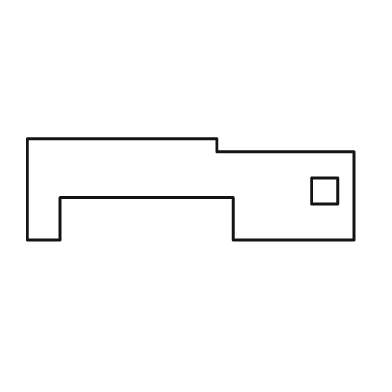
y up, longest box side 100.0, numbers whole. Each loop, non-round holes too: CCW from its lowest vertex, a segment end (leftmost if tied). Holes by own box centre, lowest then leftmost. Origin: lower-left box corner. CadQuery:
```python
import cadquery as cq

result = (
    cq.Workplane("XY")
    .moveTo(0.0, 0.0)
    .lineTo(10.0, 0.0)
    .lineTo(10.0, 13.0)
    .lineTo(63.0, 13.0)
    .lineTo(63.0, 0.0)
    .lineTo(100.0, 0.0)
    .lineTo(100.0, 27.0)
    .lineTo(58.0, 27.0)
    .lineTo(58.0, 31.0)
    .lineTo(0.0, 31.0)
    .close()
    .moveTo(87.0, 11.0)
    .lineTo(95.0, 11.0)
    .lineTo(95.0, 19.0)
    .lineTo(87.0, 19.0)
    .close()
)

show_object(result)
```